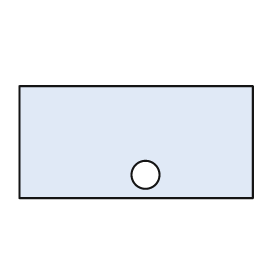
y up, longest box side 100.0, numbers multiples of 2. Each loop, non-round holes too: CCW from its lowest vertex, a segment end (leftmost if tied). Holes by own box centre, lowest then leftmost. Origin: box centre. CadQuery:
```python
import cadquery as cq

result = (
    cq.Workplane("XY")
    .moveTo(-50.0, -24.0)
    .lineTo(50.0, -24.0)
    .lineTo(50.0, 24.0)
    .lineTo(-50.0, 24.0)
    .close()
    .moveTo(4.0, -14.0)
    .circle(6.0)
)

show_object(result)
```